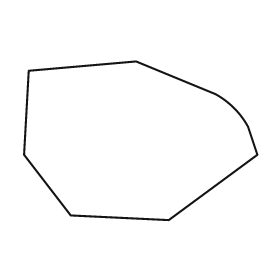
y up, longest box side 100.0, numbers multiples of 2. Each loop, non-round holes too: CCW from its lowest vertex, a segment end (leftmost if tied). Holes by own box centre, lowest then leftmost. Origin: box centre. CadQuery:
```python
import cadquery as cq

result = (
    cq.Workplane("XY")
    .moveTo(12.0, -34.0)
    .lineTo(50.0, -6.0)
    .lineTo(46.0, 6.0)
    .threePointArc((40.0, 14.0), (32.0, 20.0))
    .lineTo(-2.0, 34.0)
    .lineTo(-48.0, 30.0)
    .lineTo(-50.0, -6.0)
    .lineTo(-30.0, -32.0)
    .close()
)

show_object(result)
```